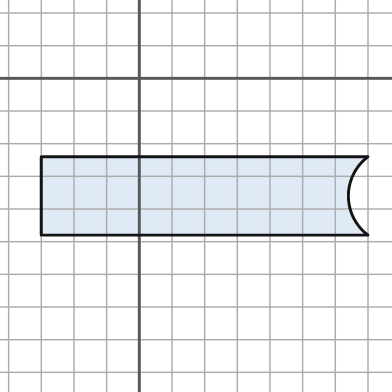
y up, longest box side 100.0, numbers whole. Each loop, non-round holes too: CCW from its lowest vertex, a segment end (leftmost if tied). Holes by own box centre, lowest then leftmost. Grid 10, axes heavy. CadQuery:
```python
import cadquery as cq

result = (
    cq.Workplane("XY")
    .moveTo(-30.0, -48.0)
    .lineTo(70.0, -48.0)
    .threePointArc((64.0, -36.0), (70.0, -24.0))
    .lineTo(-30.0, -24.0)
    .close()
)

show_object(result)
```